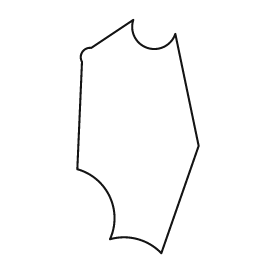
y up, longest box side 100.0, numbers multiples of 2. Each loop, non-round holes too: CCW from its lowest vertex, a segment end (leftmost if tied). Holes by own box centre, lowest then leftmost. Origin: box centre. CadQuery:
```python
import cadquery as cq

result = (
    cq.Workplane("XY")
    .moveTo(10.0, -50.0)
    .lineTo(26.0, -4.0)
    .lineTo(16.0, 44.0)
    .threePointArc((4.0, 38.0), (-2.0, 50.0))
    .lineTo(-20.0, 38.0)
    .threePointArc((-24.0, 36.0), (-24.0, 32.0))
    .lineTo(-26.0, -14.0)
    .threePointArc((-12.0, -26.0), (-12.0, -44.0))
    .threePointArc((0.0, -44.0), (10.0, -50.0))
    .close()
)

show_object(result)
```